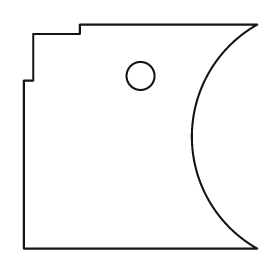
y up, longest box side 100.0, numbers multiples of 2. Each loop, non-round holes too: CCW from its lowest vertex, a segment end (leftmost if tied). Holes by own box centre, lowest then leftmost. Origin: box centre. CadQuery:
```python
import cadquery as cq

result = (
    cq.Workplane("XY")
    .moveTo(-50.0, -48.0)
    .lineTo(50.0, -48.0)
    .threePointArc((22.0, 0.0), (50.0, 48.0))
    .lineTo(-26.0, 48.0)
    .lineTo(-26.0, 44.0)
    .lineTo(-46.0, 44.0)
    .lineTo(-46.0, 24.0)
    .lineTo(-50.0, 24.0)
    .close()
    .moveTo(0.0, 26.0)
    .circle(6.0)
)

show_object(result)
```